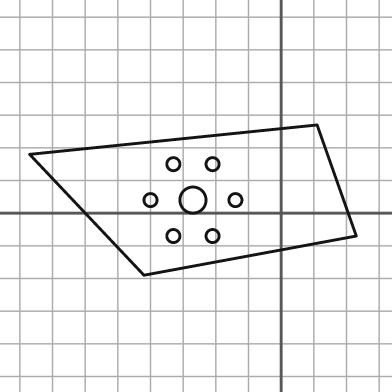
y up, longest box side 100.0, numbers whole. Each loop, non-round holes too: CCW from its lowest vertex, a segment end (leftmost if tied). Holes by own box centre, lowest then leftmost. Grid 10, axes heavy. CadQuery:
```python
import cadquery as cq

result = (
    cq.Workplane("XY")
    .moveTo(-42.0, -19.0)
    .lineTo(23.0, -7.0)
    .lineTo(11.0, 27.0)
    .lineTo(-77.0, 18.0)
    .close()
    .moveTo(-33.0, -7.0)
    .circle(2.0)
    .moveTo(-21.0, -7.0)
    .circle(2.0)
    .moveTo(-40.0, 4.0)
    .circle(2.0)
    .moveTo(-27.0, 4.0)
    .circle(4.0)
    .moveTo(-14.0, 4.0)
    .circle(2.0)
    .moveTo(-33.0, 15.0)
    .circle(2.0)
    .moveTo(-21.0, 15.0)
    .circle(2.0)
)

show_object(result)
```